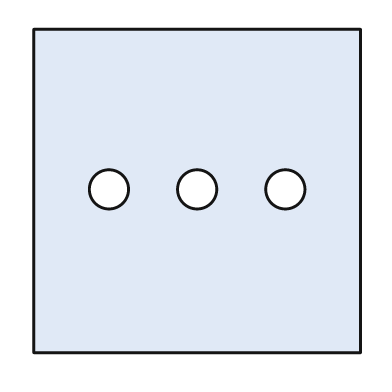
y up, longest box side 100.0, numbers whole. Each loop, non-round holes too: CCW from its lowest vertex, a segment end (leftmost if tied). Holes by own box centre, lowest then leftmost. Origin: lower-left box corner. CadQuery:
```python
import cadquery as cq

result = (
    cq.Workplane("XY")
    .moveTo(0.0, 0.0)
    .lineTo(100.0, 0.0)
    .lineTo(100.0, 99.0)
    .lineTo(0.0, 99.0)
    .close()
    .moveTo(23.0, 50.0)
    .circle(6.0)
    .moveTo(50.0, 50.0)
    .circle(6.0)
    .moveTo(77.0, 50.0)
    .circle(6.0)
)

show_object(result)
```